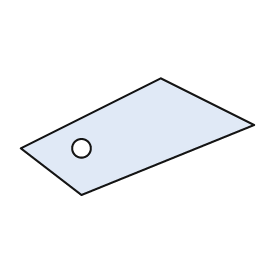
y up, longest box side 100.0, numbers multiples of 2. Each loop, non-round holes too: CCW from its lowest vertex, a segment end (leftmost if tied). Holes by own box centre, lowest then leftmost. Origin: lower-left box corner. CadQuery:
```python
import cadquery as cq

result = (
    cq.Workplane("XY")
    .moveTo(26.0, 0.0)
    .lineTo(100.0, 30.0)
    .lineTo(60.0, 50.0)
    .lineTo(0.0, 20.0)
    .close()
    .moveTo(26.0, 20.0)
    .circle(4.0)
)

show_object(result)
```